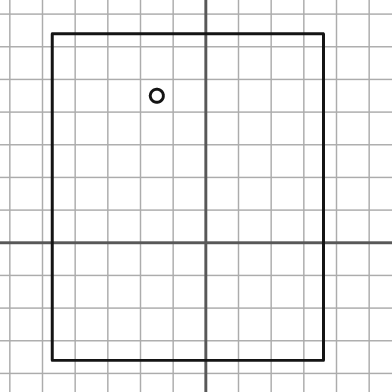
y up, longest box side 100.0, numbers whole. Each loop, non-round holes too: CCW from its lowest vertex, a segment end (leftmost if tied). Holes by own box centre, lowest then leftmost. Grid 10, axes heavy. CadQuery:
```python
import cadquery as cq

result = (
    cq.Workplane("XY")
    .moveTo(-47.0, -36.0)
    .lineTo(36.0, -36.0)
    .lineTo(36.0, 64.0)
    .lineTo(-47.0, 64.0)
    .close()
    .moveTo(-15.0, 45.0)
    .circle(2.0)
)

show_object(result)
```